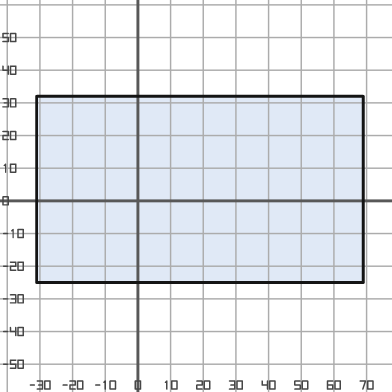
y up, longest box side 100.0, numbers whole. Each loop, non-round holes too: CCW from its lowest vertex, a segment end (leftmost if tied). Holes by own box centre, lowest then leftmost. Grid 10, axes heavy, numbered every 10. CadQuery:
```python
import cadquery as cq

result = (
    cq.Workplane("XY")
    .moveTo(-31.0, -25.0)
    .lineTo(69.0, -25.0)
    .lineTo(69.0, 32.0)
    .lineTo(-31.0, 32.0)
    .close()
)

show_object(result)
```